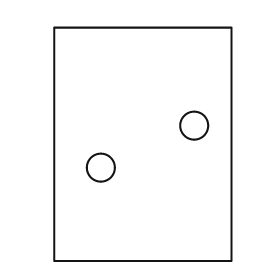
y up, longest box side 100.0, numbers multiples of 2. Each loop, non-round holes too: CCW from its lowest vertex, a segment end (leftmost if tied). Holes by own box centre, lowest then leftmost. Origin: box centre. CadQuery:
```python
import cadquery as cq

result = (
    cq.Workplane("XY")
    .moveTo(-38.0, -50.0)
    .lineTo(38.0, -50.0)
    .lineTo(38.0, 50.0)
    .lineTo(-38.0, 50.0)
    .close()
    .moveTo(-18.0, -10.0)
    .circle(6.0)
    .moveTo(22.0, 8.0)
    .circle(6.0)
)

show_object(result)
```